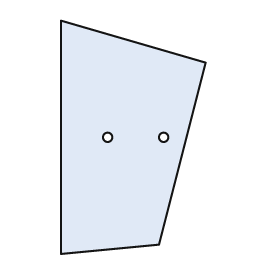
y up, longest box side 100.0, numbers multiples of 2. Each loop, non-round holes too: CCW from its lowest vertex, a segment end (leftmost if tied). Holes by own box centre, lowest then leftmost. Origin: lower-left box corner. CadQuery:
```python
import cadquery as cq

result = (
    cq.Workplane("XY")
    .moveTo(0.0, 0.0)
    .lineTo(42.0, 4.0)
    .lineTo(62.0, 82.0)
    .lineTo(0.0, 100.0)
    .close()
    .moveTo(20.0, 50.0)
    .circle(2.0)
    .moveTo(44.0, 50.0)
    .circle(2.0)
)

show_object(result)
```